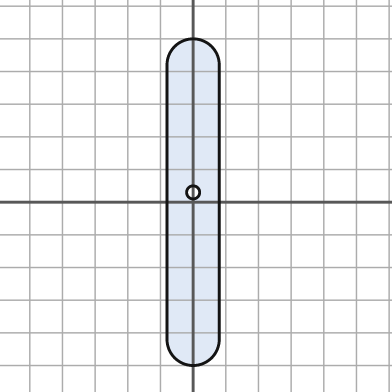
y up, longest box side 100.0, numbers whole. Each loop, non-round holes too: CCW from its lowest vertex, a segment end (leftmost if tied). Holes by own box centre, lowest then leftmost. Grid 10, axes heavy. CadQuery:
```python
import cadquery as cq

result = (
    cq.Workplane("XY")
    .moveTo(-8.0, -42.0)
    .threePointArc((0.0, -50.0), (8.0, -42.0))
    .lineTo(8.0, 42.0)
    .threePointArc((0.0, 50.0), (-8.0, 42.0))
    .close()
    .moveTo(0.0, 3.0)
    .circle(2.0)
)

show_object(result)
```